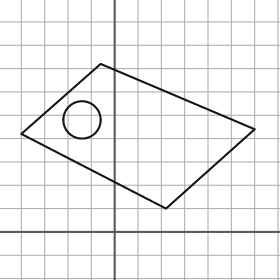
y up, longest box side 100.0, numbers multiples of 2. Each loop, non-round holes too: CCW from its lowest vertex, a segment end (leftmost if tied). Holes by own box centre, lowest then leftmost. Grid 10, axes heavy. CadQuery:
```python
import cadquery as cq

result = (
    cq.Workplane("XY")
    .moveTo(22.0, 10.0)
    .lineTo(60.0, 44.0)
    .lineTo(-6.0, 72.0)
    .lineTo(-40.0, 42.0)
    .close()
    .moveTo(-14.0, 48.0)
    .circle(8.0)
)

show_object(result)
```